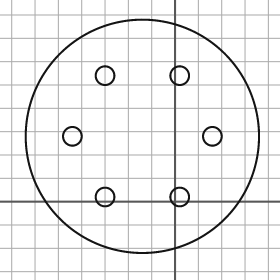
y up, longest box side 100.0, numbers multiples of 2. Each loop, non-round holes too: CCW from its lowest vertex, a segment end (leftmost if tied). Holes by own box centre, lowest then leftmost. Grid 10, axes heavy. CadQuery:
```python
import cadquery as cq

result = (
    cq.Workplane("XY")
    .moveTo(-14.0, 28.0)
    .circle(50.0)
    .moveTo(-30.0, 2.0)
    .circle(4.0)
    .moveTo(2.0, 2.0)
    .circle(4.0)
    .moveTo(-44.0, 28.0)
    .circle(4.0)
    .moveTo(16.0, 28.0)
    .circle(4.0)
    .moveTo(-30.0, 54.0)
    .circle(4.0)
    .moveTo(2.0, 54.0)
    .circle(4.0)
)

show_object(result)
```